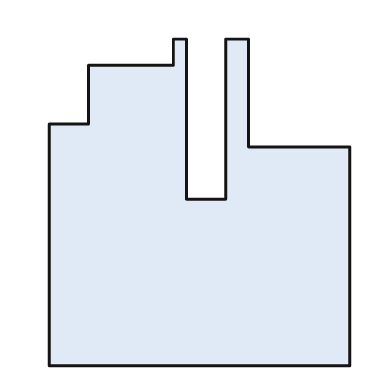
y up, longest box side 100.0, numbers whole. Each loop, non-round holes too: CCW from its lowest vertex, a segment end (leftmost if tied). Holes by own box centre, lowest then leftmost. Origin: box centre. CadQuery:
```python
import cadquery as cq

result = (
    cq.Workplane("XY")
    .moveTo(-46.0, -50.0)
    .lineTo(46.0, -50.0)
    .lineTo(46.0, 17.0)
    .lineTo(15.0, 17.0)
    .lineTo(15.0, 50.0)
    .lineTo(8.0, 50.0)
    .lineTo(8.0, 1.0)
    .lineTo(-4.0, 1.0)
    .lineTo(-4.0, 50.0)
    .lineTo(-8.0, 50.0)
    .lineTo(-8.0, 42.0)
    .lineTo(-34.0, 42.0)
    .lineTo(-34.0, 24.0)
    .lineTo(-46.0, 24.0)
    .close()
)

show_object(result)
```